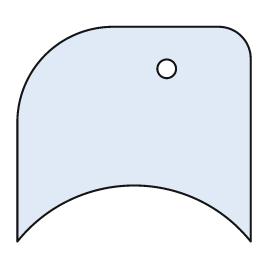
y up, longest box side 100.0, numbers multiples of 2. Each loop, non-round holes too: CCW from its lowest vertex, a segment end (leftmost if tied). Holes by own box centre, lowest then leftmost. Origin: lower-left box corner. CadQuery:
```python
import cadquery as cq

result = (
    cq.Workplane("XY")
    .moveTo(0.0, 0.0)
    .threePointArc((50.0, 24.0), (100.0, 0.0))
    .lineTo(100.0, 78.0)
    .threePointArc((96.0, 88.0), (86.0, 92.0))
    .lineTo(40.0, 92.0)
    .threePointArc((12.0, 80.0), (0.0, 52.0))
    .close()
    .moveTo(64.0, 74.0)
    .circle(4.0)
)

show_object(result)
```